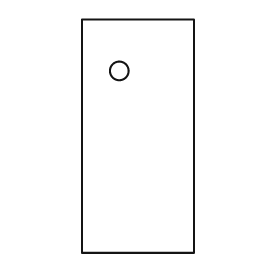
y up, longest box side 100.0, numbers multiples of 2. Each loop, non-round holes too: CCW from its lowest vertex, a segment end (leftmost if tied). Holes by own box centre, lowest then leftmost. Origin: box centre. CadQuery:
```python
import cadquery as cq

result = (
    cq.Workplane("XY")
    .moveTo(-24.0, -50.0)
    .lineTo(24.0, -50.0)
    .lineTo(24.0, 50.0)
    .lineTo(-24.0, 50.0)
    .close()
    .moveTo(-8.0, 28.0)
    .circle(4.0)
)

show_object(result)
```